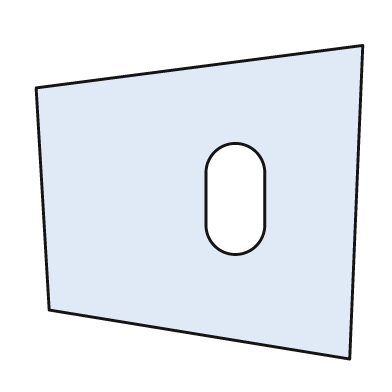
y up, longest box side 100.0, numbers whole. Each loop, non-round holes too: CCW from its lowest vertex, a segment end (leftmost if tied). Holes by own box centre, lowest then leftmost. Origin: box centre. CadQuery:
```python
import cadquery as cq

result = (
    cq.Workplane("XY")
    .moveTo(46.0, -48.0)
    .lineTo(50.0, 48.0)
    .lineTo(-50.0, 35.0)
    .lineTo(-46.0, -33.0)
    .close()
    .moveTo(2.0, -7.0)
    .threePointArc((11.0, -16.0), (20.0, -7.0))
    .lineTo(20.0, 9.0)
    .threePointArc((11.0, 18.0), (2.0, 9.0))
    .close()
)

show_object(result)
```